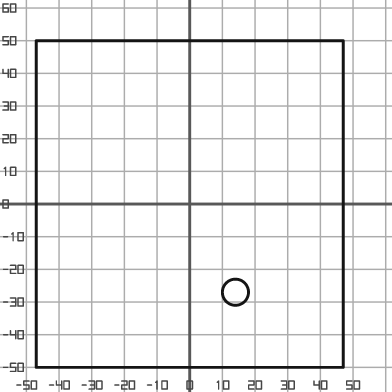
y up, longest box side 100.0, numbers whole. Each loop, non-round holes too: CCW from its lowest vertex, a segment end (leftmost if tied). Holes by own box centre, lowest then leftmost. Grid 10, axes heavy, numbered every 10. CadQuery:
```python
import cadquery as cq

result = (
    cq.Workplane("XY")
    .moveTo(-47.0, -50.0)
    .lineTo(47.0, -50.0)
    .lineTo(47.0, 50.0)
    .lineTo(-47.0, 50.0)
    .close()
    .moveTo(14.0, -27.0)
    .circle(4.0)
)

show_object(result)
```